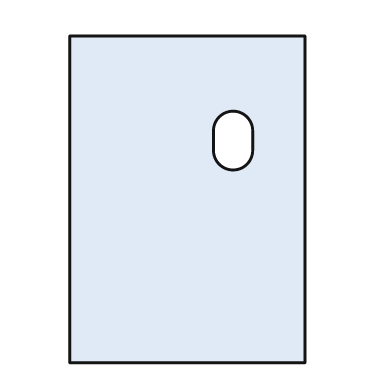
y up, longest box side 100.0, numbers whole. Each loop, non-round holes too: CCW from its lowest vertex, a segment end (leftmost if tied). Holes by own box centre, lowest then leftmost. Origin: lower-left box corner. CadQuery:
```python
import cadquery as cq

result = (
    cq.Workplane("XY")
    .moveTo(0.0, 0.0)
    .lineTo(72.0, 0.0)
    .lineTo(72.0, 100.0)
    .lineTo(0.0, 100.0)
    .close()
    .moveTo(44.0, 65.0)
    .threePointArc((50.0, 59.0), (56.0, 65.0))
    .lineTo(56.0, 71.0)
    .threePointArc((50.0, 77.0), (44.0, 71.0))
    .close()
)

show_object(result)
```